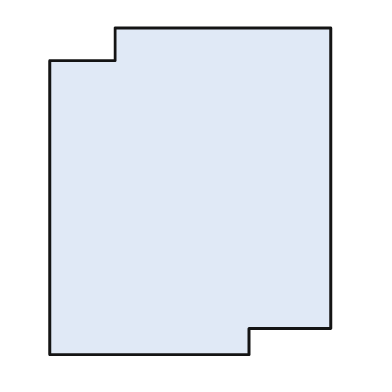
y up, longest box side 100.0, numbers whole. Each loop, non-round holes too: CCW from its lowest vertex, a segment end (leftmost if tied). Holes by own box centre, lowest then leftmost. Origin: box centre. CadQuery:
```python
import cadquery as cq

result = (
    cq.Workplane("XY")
    .moveTo(-43.0, -50.0)
    .lineTo(18.0, -50.0)
    .lineTo(18.0, -42.0)
    .lineTo(43.0, -42.0)
    .lineTo(43.0, 50.0)
    .lineTo(-23.0, 50.0)
    .lineTo(-23.0, 40.0)
    .lineTo(-43.0, 40.0)
    .close()
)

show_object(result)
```